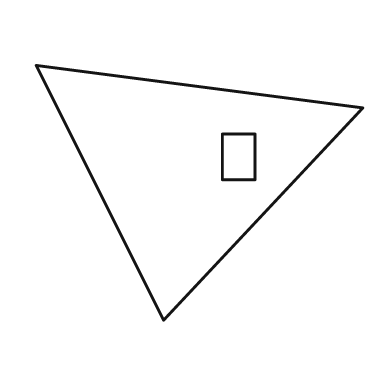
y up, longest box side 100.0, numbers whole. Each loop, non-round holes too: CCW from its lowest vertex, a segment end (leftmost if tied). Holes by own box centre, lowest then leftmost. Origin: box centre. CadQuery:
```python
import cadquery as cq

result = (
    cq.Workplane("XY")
    .moveTo(-11.0, -39.0)
    .lineTo(50.0, 26.0)
    .lineTo(-50.0, 39.0)
    .close()
    .moveTo(7.0, 4.0)
    .lineTo(17.0, 4.0)
    .lineTo(17.0, 18.0)
    .lineTo(7.0, 18.0)
    .close()
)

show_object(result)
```